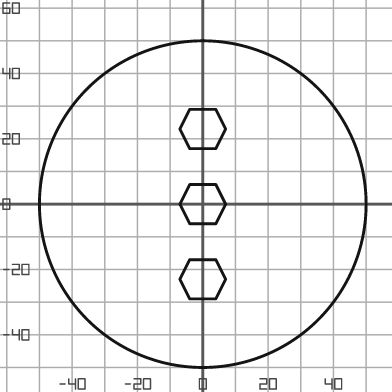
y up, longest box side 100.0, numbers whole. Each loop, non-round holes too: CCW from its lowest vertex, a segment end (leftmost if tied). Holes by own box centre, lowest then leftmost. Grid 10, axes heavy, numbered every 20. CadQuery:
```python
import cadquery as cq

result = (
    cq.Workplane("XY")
    .moveTo(0.0, 0.0)
    .circle(50.0)
    .moveTo(-4.0, -29.0)
    .lineTo(4.0, -29.0)
    .lineTo(7.0, -23.0)
    .lineTo(4.0, -17.0)
    .lineTo(-4.0, -17.0)
    .lineTo(-7.0, -23.0)
    .close()
    .moveTo(-4.0, -6.0)
    .lineTo(4.0, -6.0)
    .lineTo(7.0, 0.0)
    .lineTo(4.0, 6.0)
    .lineTo(-4.0, 6.0)
    .lineTo(-7.0, 0.0)
    .close()
    .moveTo(-4.0, 17.0)
    .lineTo(4.0, 17.0)
    .lineTo(7.0, 23.0)
    .lineTo(4.0, 29.0)
    .lineTo(-4.0, 29.0)
    .lineTo(-7.0, 23.0)
    .close()
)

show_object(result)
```